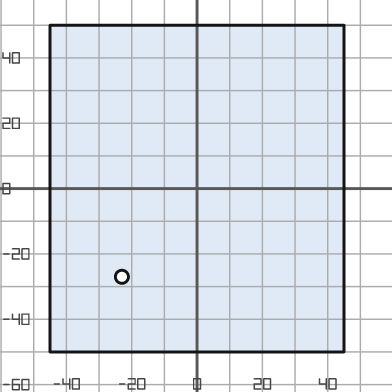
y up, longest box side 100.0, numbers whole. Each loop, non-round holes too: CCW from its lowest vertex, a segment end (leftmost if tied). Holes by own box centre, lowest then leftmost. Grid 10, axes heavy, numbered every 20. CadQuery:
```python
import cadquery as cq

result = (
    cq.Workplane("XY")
    .moveTo(-45.0, -50.0)
    .lineTo(45.0, -50.0)
    .lineTo(45.0, 50.0)
    .lineTo(-45.0, 50.0)
    .close()
    .moveTo(-23.0, -27.0)
    .circle(2.0)
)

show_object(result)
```